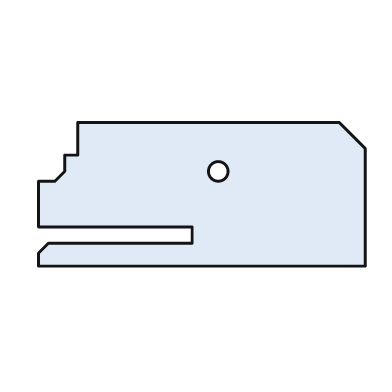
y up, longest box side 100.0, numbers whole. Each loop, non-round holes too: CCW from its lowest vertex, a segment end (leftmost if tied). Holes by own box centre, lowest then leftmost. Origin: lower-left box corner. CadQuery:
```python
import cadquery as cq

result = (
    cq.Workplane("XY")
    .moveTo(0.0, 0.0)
    .lineTo(100.0, 0.0)
    .lineTo(100.0, 36.0)
    .lineTo(92.0, 44.0)
    .lineTo(12.0, 44.0)
    .lineTo(12.0, 34.0)
    .lineTo(8.0, 34.0)
    .lineTo(8.0, 29.0)
    .lineTo(5.0, 26.0)
    .lineTo(0.0, 26.0)
    .lineTo(0.0, 12.0)
    .lineTo(47.0, 12.0)
    .lineTo(47.0, 7.0)
    .lineTo(3.0, 7.0)
    .lineTo(0.0, 4.0)
    .close()
    .moveTo(55.0, 29.0)
    .circle(3.0)
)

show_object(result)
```